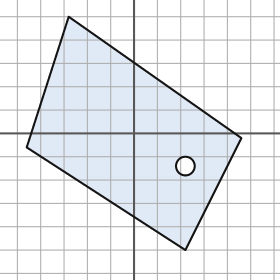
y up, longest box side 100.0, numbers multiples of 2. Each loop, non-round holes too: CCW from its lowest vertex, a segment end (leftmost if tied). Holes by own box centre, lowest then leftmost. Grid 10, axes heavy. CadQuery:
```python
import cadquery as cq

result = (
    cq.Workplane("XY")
    .moveTo(22.0, -50.0)
    .lineTo(46.0, -2.0)
    .lineTo(-28.0, 50.0)
    .lineTo(-46.0, -6.0)
    .close()
    .moveTo(22.0, -14.0)
    .circle(4.0)
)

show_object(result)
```